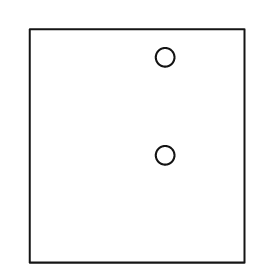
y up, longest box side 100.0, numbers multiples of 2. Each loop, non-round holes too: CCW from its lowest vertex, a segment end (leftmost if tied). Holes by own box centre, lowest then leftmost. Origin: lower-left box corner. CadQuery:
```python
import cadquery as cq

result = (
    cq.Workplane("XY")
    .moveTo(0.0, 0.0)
    .lineTo(92.0, 0.0)
    .lineTo(92.0, 100.0)
    .lineTo(0.0, 100.0)
    .close()
    .moveTo(58.0, 46.0)
    .circle(4.0)
    .moveTo(58.0, 88.0)
    .circle(4.0)
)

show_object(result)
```